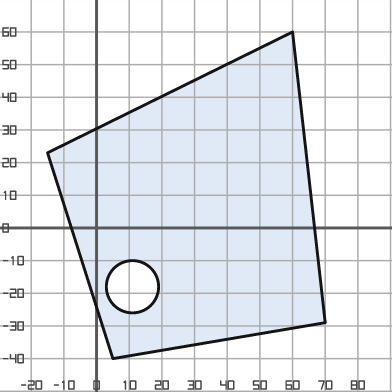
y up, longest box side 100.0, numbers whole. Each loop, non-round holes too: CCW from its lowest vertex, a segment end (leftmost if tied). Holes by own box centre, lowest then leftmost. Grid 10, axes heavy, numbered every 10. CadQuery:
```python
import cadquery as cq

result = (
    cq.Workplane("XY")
    .moveTo(5.0, -40.0)
    .lineTo(70.0, -29.0)
    .lineTo(60.0, 60.0)
    .lineTo(-15.0, 23.0)
    .close()
    .moveTo(11.0, -18.0)
    .circle(8.0)
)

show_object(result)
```